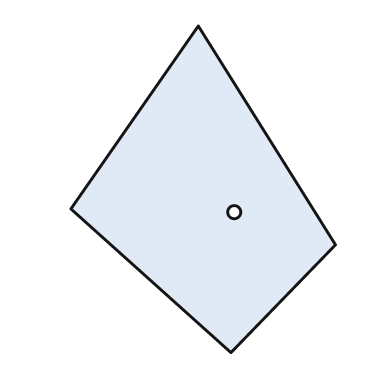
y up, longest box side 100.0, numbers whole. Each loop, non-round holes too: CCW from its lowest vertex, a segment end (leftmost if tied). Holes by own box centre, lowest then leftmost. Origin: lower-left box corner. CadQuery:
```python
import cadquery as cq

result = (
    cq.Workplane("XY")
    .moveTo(49.0, 0.0)
    .lineTo(81.0, 33.0)
    .lineTo(39.0, 100.0)
    .lineTo(0.0, 44.0)
    .close()
    .moveTo(50.0, 43.0)
    .circle(2.0)
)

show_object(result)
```